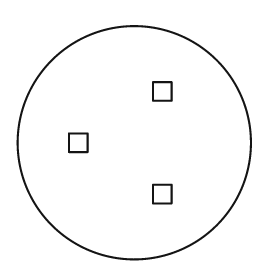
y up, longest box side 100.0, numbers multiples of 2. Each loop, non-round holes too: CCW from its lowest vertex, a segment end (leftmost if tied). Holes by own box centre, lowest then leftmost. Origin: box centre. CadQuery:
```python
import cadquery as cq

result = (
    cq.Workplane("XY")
    .moveTo(0.0, 0.0)
    .circle(50.0)
    .moveTo(8.0, -26.0)
    .lineTo(16.0, -26.0)
    .lineTo(16.0, -18.0)
    .lineTo(8.0, -18.0)
    .close()
    .moveTo(-28.0, -4.0)
    .lineTo(-20.0, -4.0)
    .lineTo(-20.0, 4.0)
    .lineTo(-28.0, 4.0)
    .close()
    .moveTo(8.0, 18.0)
    .lineTo(16.0, 18.0)
    .lineTo(16.0, 26.0)
    .lineTo(8.0, 26.0)
    .close()
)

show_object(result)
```